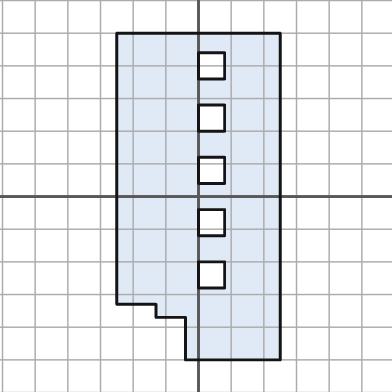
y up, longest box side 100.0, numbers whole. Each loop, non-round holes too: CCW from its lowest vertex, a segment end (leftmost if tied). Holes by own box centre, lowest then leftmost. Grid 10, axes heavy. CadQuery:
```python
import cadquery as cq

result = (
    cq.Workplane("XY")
    .moveTo(-4.0, -50.0)
    .lineTo(25.0, -50.0)
    .lineTo(25.0, 50.0)
    .lineTo(-25.0, 50.0)
    .lineTo(-25.0, -33.0)
    .lineTo(-13.0, -33.0)
    .lineTo(-13.0, -37.0)
    .lineTo(-4.0, -37.0)
    .close()
    .moveTo(0.0, -28.0)
    .lineTo(8.0, -28.0)
    .lineTo(8.0, -20.0)
    .lineTo(0.0, -20.0)
    .close()
    .moveTo(0.0, -12.0)
    .lineTo(8.0, -12.0)
    .lineTo(8.0, -4.0)
    .lineTo(0.0, -4.0)
    .close()
    .moveTo(0.0, 4.0)
    .lineTo(8.0, 4.0)
    .lineTo(8.0, 12.0)
    .lineTo(0.0, 12.0)
    .close()
    .moveTo(0.0, 20.0)
    .lineTo(8.0, 20.0)
    .lineTo(8.0, 28.0)
    .lineTo(0.0, 28.0)
    .close()
    .moveTo(0.0, 36.0)
    .lineTo(8.0, 36.0)
    .lineTo(8.0, 44.0)
    .lineTo(0.0, 44.0)
    .close()
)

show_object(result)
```